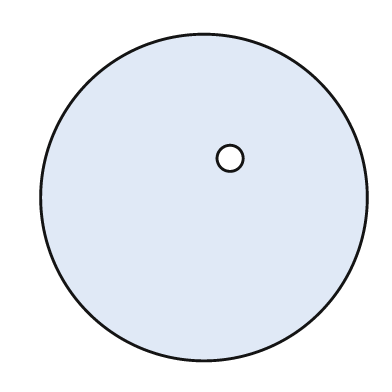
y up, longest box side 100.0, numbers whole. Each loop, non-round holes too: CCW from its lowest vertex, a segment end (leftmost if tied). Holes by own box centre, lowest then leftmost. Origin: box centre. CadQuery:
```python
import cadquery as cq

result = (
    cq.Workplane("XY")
    .moveTo(0.0, 0.0)
    .circle(50.0)
    .moveTo(8.0, 12.0)
    .circle(4.0)
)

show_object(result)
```